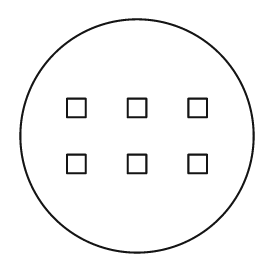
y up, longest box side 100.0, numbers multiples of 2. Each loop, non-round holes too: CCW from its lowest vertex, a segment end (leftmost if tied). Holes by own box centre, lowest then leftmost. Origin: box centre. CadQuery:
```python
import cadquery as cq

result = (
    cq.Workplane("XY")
    .moveTo(0.0, 0.0)
    .circle(50.0)
    .moveTo(-30.0, -16.0)
    .lineTo(-22.0, -16.0)
    .lineTo(-22.0, -8.0)
    .lineTo(-30.0, -8.0)
    .close()
    .moveTo(-4.0, -16.0)
    .lineTo(4.0, -16.0)
    .lineTo(4.0, -8.0)
    .lineTo(-4.0, -8.0)
    .close()
    .moveTo(22.0, -16.0)
    .lineTo(30.0, -16.0)
    .lineTo(30.0, -8.0)
    .lineTo(22.0, -8.0)
    .close()
    .moveTo(-30.0, 8.0)
    .lineTo(-22.0, 8.0)
    .lineTo(-22.0, 16.0)
    .lineTo(-30.0, 16.0)
    .close()
    .moveTo(-4.0, 8.0)
    .lineTo(4.0, 8.0)
    .lineTo(4.0, 16.0)
    .lineTo(-4.0, 16.0)
    .close()
    .moveTo(22.0, 8.0)
    .lineTo(30.0, 8.0)
    .lineTo(30.0, 16.0)
    .lineTo(22.0, 16.0)
    .close()
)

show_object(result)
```